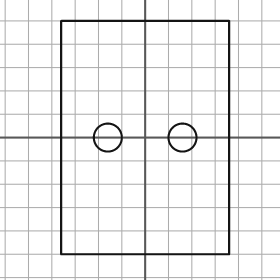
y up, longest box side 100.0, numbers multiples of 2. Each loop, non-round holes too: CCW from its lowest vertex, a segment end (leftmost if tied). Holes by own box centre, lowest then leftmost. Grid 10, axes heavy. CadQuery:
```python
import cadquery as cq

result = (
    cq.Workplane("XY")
    .moveTo(-36.0, -50.0)
    .lineTo(36.0, -50.0)
    .lineTo(36.0, 50.0)
    .lineTo(-36.0, 50.0)
    .close()
    .moveTo(-16.0, 0.0)
    .circle(6.0)
    .moveTo(16.0, 0.0)
    .circle(6.0)
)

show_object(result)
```